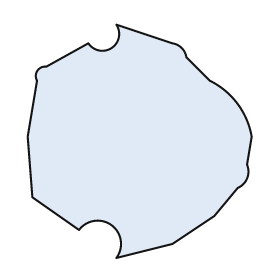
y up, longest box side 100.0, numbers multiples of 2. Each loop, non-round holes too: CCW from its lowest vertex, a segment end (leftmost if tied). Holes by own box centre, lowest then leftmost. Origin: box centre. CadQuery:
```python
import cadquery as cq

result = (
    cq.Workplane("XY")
    .moveTo(-10.0, -50.0)
    .lineTo(14.0, -44.0)
    .lineTo(32.0, -32.0)
    .lineTo(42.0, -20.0)
    .threePointArc((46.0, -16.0), (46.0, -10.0))
    .lineTo(48.0, 2.0)
    .threePointArc((42.0, 16.0), (30.0, 26.0))
    .lineTo(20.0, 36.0)
    .threePointArc((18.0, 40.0), (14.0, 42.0))
    .lineTo(-10.0, 50.0)
    .threePointArc((-12.0, 40.0), (-22.0, 42.0))
    .lineTo(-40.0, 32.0)
    .threePointArc((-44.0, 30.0), (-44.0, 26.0))
    .lineTo(-48.0, 2.0)
    .lineTo(-46.0, -24.0)
    .lineTo(-26.0, -38.0)
    .threePointArc((-12.0, -36.0), (-10.0, -50.0))
    .close()
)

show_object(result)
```